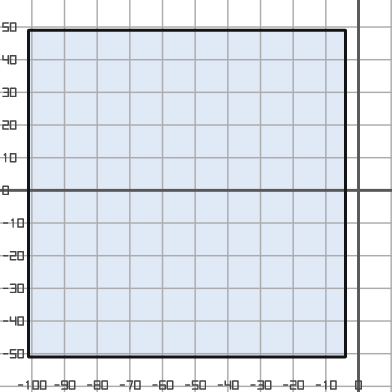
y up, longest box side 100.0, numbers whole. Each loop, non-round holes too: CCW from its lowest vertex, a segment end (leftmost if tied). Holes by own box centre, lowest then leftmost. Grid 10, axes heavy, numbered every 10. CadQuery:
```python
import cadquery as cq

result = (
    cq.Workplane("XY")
    .moveTo(-101.0, -51.0)
    .lineTo(-4.0, -51.0)
    .lineTo(-4.0, 49.0)
    .lineTo(-101.0, 49.0)
    .close()
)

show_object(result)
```